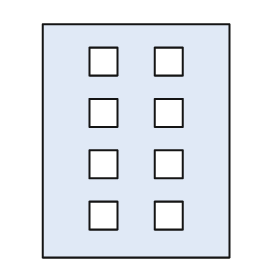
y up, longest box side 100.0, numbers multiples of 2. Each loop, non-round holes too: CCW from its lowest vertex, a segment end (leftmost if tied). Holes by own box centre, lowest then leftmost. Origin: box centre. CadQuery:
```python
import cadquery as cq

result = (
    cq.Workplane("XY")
    .moveTo(-40.0, -50.0)
    .lineTo(40.0, -50.0)
    .lineTo(40.0, 50.0)
    .lineTo(-40.0, 50.0)
    .close()
    .moveTo(-20.0, -38.0)
    .lineTo(-8.0, -38.0)
    .lineTo(-8.0, -26.0)
    .lineTo(-20.0, -26.0)
    .close()
    .moveTo(8.0, -38.0)
    .lineTo(20.0, -38.0)
    .lineTo(20.0, -26.0)
    .lineTo(8.0, -26.0)
    .close()
    .moveTo(-20.0, -16.0)
    .lineTo(-8.0, -16.0)
    .lineTo(-8.0, -4.0)
    .lineTo(-20.0, -4.0)
    .close()
    .moveTo(8.0, -16.0)
    .lineTo(20.0, -16.0)
    .lineTo(20.0, -4.0)
    .lineTo(8.0, -4.0)
    .close()
    .moveTo(-20.0, 6.0)
    .lineTo(-8.0, 6.0)
    .lineTo(-8.0, 18.0)
    .lineTo(-20.0, 18.0)
    .close()
    .moveTo(8.0, 6.0)
    .lineTo(20.0, 6.0)
    .lineTo(20.0, 18.0)
    .lineTo(8.0, 18.0)
    .close()
    .moveTo(-20.0, 28.0)
    .lineTo(-8.0, 28.0)
    .lineTo(-8.0, 40.0)
    .lineTo(-20.0, 40.0)
    .close()
    .moveTo(8.0, 28.0)
    .lineTo(20.0, 28.0)
    .lineTo(20.0, 40.0)
    .lineTo(8.0, 40.0)
    .close()
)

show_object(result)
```